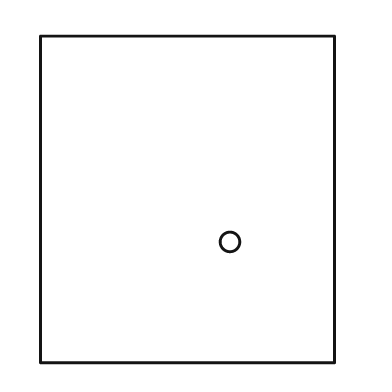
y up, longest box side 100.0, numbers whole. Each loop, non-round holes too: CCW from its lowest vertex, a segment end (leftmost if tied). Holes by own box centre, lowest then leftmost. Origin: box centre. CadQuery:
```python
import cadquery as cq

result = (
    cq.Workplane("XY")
    .moveTo(-45.0, -50.0)
    .lineTo(45.0, -50.0)
    .lineTo(45.0, 50.0)
    .lineTo(-45.0, 50.0)
    .close()
    .moveTo(13.0, -13.0)
    .circle(3.0)
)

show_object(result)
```